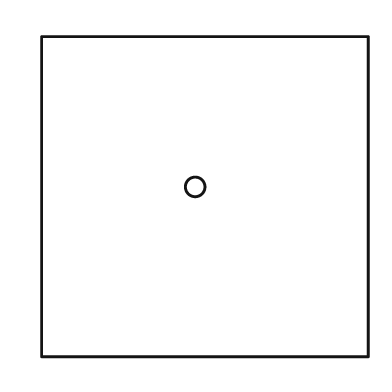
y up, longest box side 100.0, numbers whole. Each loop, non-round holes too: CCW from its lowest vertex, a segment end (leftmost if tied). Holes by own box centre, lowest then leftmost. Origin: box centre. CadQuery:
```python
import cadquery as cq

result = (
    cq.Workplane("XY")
    .moveTo(-50.0, -49.0)
    .lineTo(50.0, -49.0)
    .lineTo(50.0, 49.0)
    .lineTo(-50.0, 49.0)
    .close()
    .moveTo(-3.0, 3.0)
    .circle(3.0)
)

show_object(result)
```